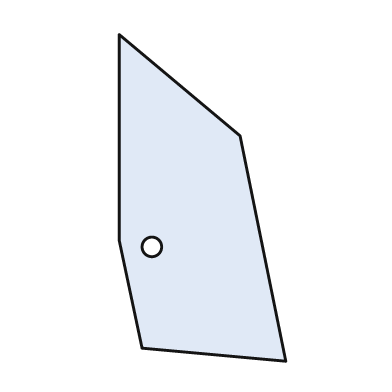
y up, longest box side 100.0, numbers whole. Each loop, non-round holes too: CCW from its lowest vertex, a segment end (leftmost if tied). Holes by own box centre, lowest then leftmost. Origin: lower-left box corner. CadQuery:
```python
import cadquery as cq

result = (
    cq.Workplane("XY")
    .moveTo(51.0, 0.0)
    .lineTo(37.0, 69.0)
    .lineTo(0.0, 100.0)
    .lineTo(0.0, 37.0)
    .lineTo(7.0, 4.0)
    .close()
    .moveTo(10.0, 35.0)
    .circle(3.0)
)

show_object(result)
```